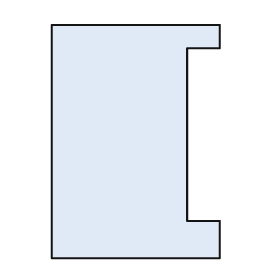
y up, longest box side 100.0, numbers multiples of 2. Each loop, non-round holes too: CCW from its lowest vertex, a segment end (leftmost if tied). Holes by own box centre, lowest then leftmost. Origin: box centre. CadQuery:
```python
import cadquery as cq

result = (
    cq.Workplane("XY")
    .moveTo(-36.0, -50.0)
    .lineTo(36.0, -50.0)
    .lineTo(36.0, -34.0)
    .lineTo(22.0, -34.0)
    .lineTo(22.0, 40.0)
    .lineTo(36.0, 40.0)
    .lineTo(36.0, 50.0)
    .lineTo(-36.0, 50.0)
    .close()
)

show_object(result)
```